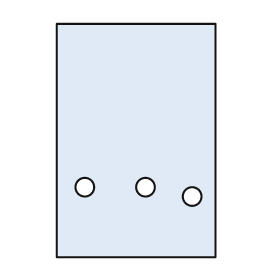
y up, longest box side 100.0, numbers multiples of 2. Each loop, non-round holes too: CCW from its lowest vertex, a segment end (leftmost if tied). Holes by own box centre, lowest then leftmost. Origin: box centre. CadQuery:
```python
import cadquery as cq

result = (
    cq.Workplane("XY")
    .moveTo(-34.0, -50.0)
    .lineTo(34.0, -50.0)
    .lineTo(34.0, 50.0)
    .lineTo(-34.0, 50.0)
    .close()
    .moveTo(24.0, -24.0)
    .circle(4.0)
    .moveTo(-22.0, -20.0)
    .circle(4.0)
    .moveTo(4.0, -20.0)
    .circle(4.0)
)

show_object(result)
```